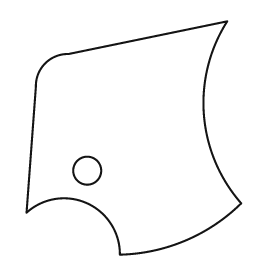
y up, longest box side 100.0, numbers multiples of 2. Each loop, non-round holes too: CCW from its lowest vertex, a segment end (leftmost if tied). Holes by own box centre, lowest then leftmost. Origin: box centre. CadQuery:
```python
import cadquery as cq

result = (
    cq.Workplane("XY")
    .moveTo(-6.0, -50.0)
    .threePointArc((22.0, -44.0), (46.0, -28.0))
    .threePointArc((30.0, 10.0), (40.0, 50.0))
    .lineTo(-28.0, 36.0)
    .threePointArc((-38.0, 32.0), (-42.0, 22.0))
    .lineTo(-46.0, -32.0)
    .threePointArc((-20.0, -28.0), (-6.0, -50.0))
    .close()
    .moveTo(-20.0, -14.0)
    .circle(6.0)
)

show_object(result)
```